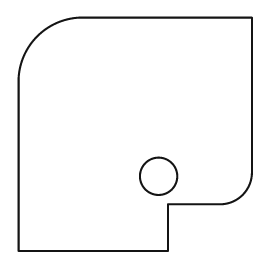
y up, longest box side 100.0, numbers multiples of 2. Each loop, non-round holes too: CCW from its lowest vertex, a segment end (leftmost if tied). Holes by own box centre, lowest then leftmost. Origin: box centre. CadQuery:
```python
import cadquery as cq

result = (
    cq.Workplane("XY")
    .moveTo(-50.0, -50.0)
    .lineTo(14.0, -50.0)
    .lineTo(14.0, -30.0)
    .lineTo(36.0, -30.0)
    .threePointArc((46.0, -26.0), (50.0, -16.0))
    .lineTo(50.0, 50.0)
    .lineTo(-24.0, 50.0)
    .threePointArc((-42.0, 42.0), (-50.0, 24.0))
    .close()
    .moveTo(10.0, -18.0)
    .circle(8.0)
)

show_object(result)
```